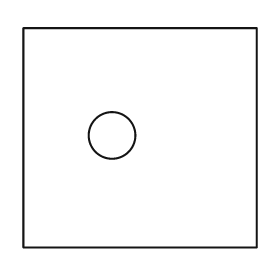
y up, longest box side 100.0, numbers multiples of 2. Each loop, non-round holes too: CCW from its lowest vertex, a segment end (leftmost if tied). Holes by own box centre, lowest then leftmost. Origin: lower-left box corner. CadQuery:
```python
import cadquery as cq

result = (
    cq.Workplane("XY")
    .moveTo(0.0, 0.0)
    .lineTo(100.0, 0.0)
    .lineTo(100.0, 94.0)
    .lineTo(0.0, 94.0)
    .close()
    .moveTo(38.0, 48.0)
    .circle(10.0)
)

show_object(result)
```